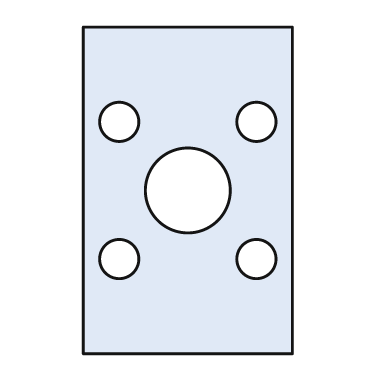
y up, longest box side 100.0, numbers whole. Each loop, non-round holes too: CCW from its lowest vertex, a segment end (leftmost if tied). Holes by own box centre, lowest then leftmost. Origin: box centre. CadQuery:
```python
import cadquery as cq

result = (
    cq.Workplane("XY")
    .moveTo(-32.0, -50.0)
    .lineTo(32.0, -50.0)
    .lineTo(32.0, 50.0)
    .lineTo(-32.0, 50.0)
    .close()
    .moveTo(-21.0, -21.0)
    .circle(6.0)
    .moveTo(21.0, -21.0)
    .circle(6.0)
    .moveTo(0.0, 0.0)
    .circle(13.0)
    .moveTo(-21.0, 21.0)
    .circle(6.0)
    .moveTo(21.0, 21.0)
    .circle(6.0)
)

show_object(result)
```